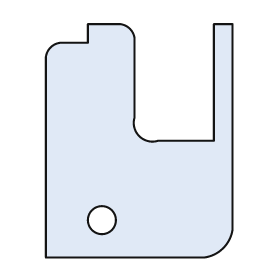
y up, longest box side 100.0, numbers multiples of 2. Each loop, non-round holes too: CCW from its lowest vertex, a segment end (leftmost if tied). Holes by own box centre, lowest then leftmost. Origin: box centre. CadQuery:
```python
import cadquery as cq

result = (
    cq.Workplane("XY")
    .moveTo(-40.0, -50.0)
    .lineTo(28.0, -50.0)
    .threePointArc((36.0, -46.0), (40.0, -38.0))
    .lineTo(40.0, 50.0)
    .lineTo(32.0, 50.0)
    .lineTo(32.0, 0.0)
    .lineTo(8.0, 0.0)
    .threePointArc((0.0, 2.0), (-2.0, 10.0))
    .lineTo(-2.0, 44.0)
    .threePointArc((-4.0, 48.0), (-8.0, 50.0))
    .lineTo(-22.0, 50.0)
    .lineTo(-22.0, 42.0)
    .lineTo(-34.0, 42.0)
    .threePointArc((-38.0, 40.0), (-40.0, 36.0))
    .close()
    .moveTo(-16.0, -34.0)
    .circle(6.0)
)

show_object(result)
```